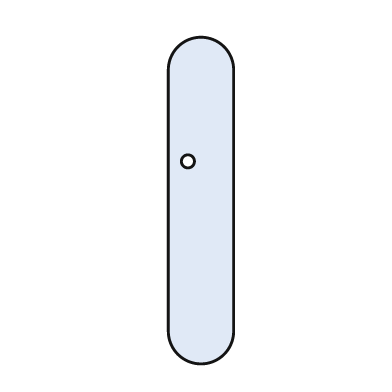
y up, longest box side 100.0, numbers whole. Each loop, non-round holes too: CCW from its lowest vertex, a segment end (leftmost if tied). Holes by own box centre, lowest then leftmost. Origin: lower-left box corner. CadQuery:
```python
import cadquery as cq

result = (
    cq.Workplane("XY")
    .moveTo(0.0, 10.0)
    .threePointArc((10.0, 0.0), (20.0, 10.0))
    .lineTo(20.0, 90.0)
    .threePointArc((10.0, 100.0), (0.0, 90.0))
    .close()
    .moveTo(6.0, 62.0)
    .circle(2.0)
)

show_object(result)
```